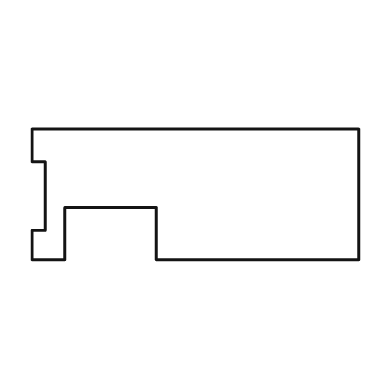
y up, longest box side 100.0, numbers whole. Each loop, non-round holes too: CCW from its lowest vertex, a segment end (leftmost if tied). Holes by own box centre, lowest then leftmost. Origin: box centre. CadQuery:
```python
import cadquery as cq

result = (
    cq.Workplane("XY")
    .moveTo(-50.0, -20.0)
    .lineTo(-40.0, -20.0)
    .lineTo(-40.0, -4.0)
    .lineTo(-12.0, -4.0)
    .lineTo(-12.0, -20.0)
    .lineTo(50.0, -20.0)
    .lineTo(50.0, 20.0)
    .lineTo(-50.0, 20.0)
    .lineTo(-50.0, 10.0)
    .lineTo(-46.0, 10.0)
    .lineTo(-46.0, -11.0)
    .lineTo(-50.0, -11.0)
    .close()
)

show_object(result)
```